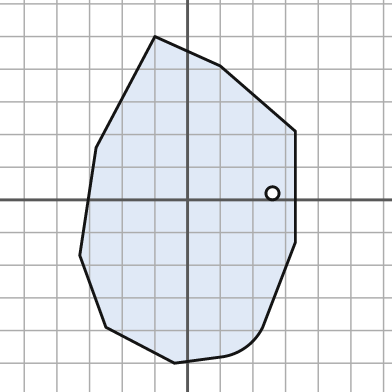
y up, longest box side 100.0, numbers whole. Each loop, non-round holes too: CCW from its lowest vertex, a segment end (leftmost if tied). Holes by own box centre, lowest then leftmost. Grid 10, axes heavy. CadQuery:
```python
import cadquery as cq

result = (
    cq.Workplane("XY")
    .moveTo(-4.0, -50.0)
    .lineTo(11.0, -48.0)
    .threePointArc((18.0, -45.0), (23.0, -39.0))
    .lineTo(33.0, -13.0)
    .lineTo(33.0, 21.0)
    .lineTo(10.0, 41.0)
    .lineTo(-10.0, 50.0)
    .lineTo(-28.0, 16.0)
    .lineTo(-33.0, -17.0)
    .lineTo(-25.0, -39.0)
    .close()
    .moveTo(26.0, 2.0)
    .circle(2.0)
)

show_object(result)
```